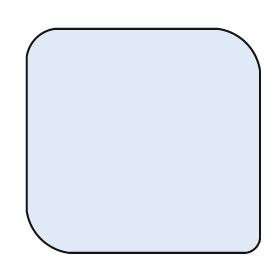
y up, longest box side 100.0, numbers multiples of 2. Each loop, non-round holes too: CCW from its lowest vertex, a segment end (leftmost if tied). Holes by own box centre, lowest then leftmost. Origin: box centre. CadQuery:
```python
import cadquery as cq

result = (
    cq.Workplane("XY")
    .moveTo(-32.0, -48.0)
    .lineTo(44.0, -48.0)
    .threePointArc((48.0, -46.0), (50.0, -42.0))
    .lineTo(50.0, 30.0)
    .threePointArc((44.0, 42.0), (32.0, 48.0))
    .lineTo(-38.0, 48.0)
    .threePointArc((-46.0, 44.0), (-50.0, 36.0))
    .lineTo(-50.0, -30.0)
    .threePointArc((-44.0, -42.0), (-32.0, -48.0))
    .close()
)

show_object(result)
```